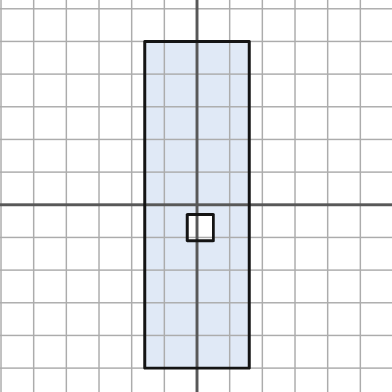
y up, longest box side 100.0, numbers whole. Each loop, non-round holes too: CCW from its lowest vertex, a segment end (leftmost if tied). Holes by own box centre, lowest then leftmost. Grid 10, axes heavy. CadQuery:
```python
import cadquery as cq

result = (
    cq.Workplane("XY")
    .moveTo(-16.0, -50.0)
    .lineTo(16.0, -50.0)
    .lineTo(16.0, 50.0)
    .lineTo(-16.0, 50.0)
    .close()
    .moveTo(-3.0, -11.0)
    .lineTo(5.0, -11.0)
    .lineTo(5.0, -3.0)
    .lineTo(-3.0, -3.0)
    .close()
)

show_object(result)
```